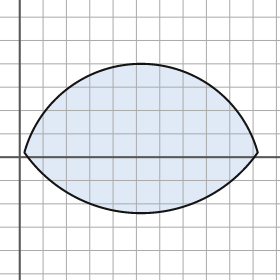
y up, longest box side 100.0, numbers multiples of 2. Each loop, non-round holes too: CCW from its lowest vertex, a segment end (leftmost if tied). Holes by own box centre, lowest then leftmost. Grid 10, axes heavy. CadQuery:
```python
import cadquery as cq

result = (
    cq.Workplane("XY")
    .moveTo(2.0, 2.0)
    .threePointArc((52.0, -24.0), (102.0, 2.0))
    .threePointArc((52.0, 40.0), (2.0, 2.0))
    .close()
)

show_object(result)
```